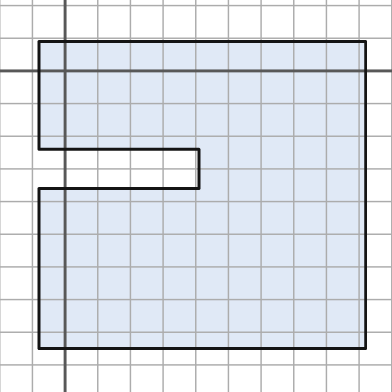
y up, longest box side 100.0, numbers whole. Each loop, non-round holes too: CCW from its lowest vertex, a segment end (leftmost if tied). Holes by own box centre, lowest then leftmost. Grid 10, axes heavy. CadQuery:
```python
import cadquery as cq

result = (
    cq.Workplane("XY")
    .moveTo(-8.0, -85.0)
    .lineTo(92.0, -85.0)
    .lineTo(92.0, 9.0)
    .lineTo(-8.0, 9.0)
    .lineTo(-8.0, -24.0)
    .lineTo(41.0, -24.0)
    .lineTo(41.0, -36.0)
    .lineTo(-8.0, -36.0)
    .close()
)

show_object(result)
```